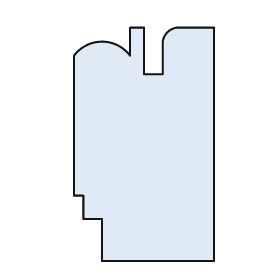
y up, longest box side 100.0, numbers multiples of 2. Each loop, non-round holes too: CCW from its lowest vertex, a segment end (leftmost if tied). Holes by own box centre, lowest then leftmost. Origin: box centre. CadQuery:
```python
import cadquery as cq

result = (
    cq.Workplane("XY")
    .moveTo(-18.0, -50.0)
    .lineTo(30.0, -50.0)
    .lineTo(30.0, 50.0)
    .lineTo(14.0, 50.0)
    .threePointArc((10.0, 48.0), (8.0, 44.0))
    .lineTo(8.0, 30.0)
    .lineTo(0.0, 30.0)
    .lineTo(0.0, 50.0)
    .lineTo(-6.0, 50.0)
    .lineTo(-6.0, 38.0)
    .threePointArc((-18.0, 44.0), (-30.0, 38.0))
    .lineTo(-30.0, -22.0)
    .lineTo(-26.0, -22.0)
    .lineTo(-26.0, -32.0)
    .lineTo(-18.0, -32.0)
    .close()
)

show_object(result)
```